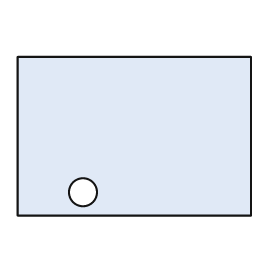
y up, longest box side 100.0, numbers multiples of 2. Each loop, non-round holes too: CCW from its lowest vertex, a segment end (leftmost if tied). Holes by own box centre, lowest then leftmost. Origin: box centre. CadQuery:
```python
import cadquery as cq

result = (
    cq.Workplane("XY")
    .moveTo(-50.0, -34.0)
    .lineTo(50.0, -34.0)
    .lineTo(50.0, 34.0)
    .lineTo(-50.0, 34.0)
    .close()
    .moveTo(-22.0, -24.0)
    .circle(6.0)
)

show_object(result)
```